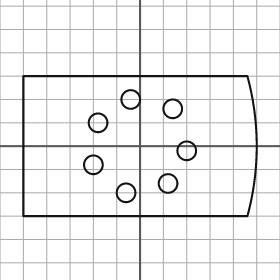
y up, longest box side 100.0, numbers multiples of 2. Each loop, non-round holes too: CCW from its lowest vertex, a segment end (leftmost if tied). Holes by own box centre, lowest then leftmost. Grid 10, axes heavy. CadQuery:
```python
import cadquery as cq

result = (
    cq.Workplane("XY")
    .moveTo(-50.0, -30.0)
    .lineTo(46.0, -30.0)
    .threePointArc((50.0, 0.0), (46.0, 30.0))
    .lineTo(-50.0, 30.0)
    .close()
    .moveTo(-6.0, -20.0)
    .circle(4.0)
    .moveTo(12.0, -16.0)
    .circle(4.0)
    .moveTo(-20.0, -8.0)
    .circle(4.0)
    .moveTo(20.0, -2.0)
    .circle(4.0)
    .moveTo(-18.0, 10.0)
    .circle(4.0)
    .moveTo(14.0, 16.0)
    .circle(4.0)
    .moveTo(-4.0, 20.0)
    .circle(4.0)
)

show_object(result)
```